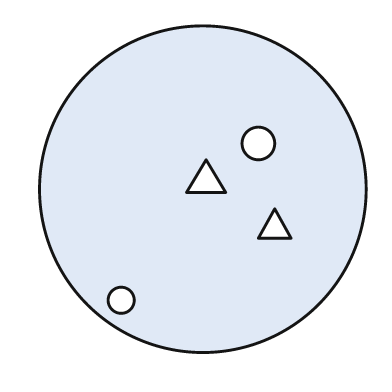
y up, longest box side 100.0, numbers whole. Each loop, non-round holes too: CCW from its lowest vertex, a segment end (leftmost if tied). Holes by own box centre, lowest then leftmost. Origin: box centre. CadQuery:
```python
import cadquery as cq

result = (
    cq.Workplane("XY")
    .moveTo(0.0, 0.0)
    .circle(50.0)
    .moveTo(-25.0, -34.0)
    .circle(4.0)
    .moveTo(17.0, -15.0)
    .lineTo(27.0, -15.0)
    .lineTo(22.0, -6.0)
    .close()
    .moveTo(-5.0, -1.0)
    .lineTo(7.0, -1.0)
    .lineTo(1.0, 9.0)
    .close()
    .moveTo(17.0, 14.0)
    .circle(5.0)
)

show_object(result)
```